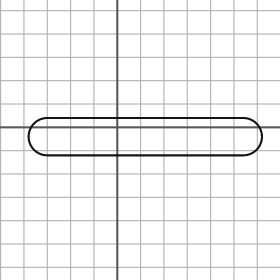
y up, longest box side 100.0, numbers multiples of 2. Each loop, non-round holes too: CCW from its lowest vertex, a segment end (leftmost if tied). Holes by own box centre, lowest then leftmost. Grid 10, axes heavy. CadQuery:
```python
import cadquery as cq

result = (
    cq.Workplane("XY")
    .moveTo(-30.0, -12.0)
    .lineTo(54.0, -12.0)
    .threePointArc((62.0, -4.0), (54.0, 4.0))
    .lineTo(-30.0, 4.0)
    .threePointArc((-38.0, -4.0), (-30.0, -12.0))
    .close()
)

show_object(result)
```